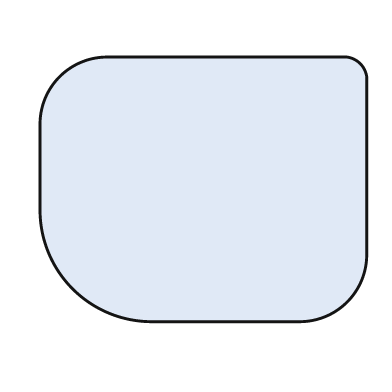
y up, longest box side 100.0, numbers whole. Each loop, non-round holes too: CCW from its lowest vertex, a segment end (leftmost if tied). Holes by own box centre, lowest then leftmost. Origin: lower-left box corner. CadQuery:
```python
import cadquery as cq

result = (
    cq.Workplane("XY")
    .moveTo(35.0, 0.0)
    .lineTo(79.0, 0.0)
    .threePointArc((94.0, 6.0), (100.0, 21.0))
    .lineTo(100.0, 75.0)
    .threePointArc((98.0, 79.0), (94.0, 81.0))
    .lineTo(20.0, 81.0)
    .threePointArc((6.0, 75.0), (0.0, 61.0))
    .lineTo(0.0, 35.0)
    .threePointArc((10.0, 10.0), (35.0, 0.0))
    .close()
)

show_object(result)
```